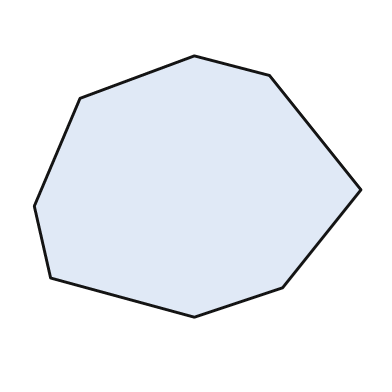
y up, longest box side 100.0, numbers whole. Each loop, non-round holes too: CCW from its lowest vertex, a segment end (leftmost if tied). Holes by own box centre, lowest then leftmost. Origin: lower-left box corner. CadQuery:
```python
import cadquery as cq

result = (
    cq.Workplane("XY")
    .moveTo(49.0, 0.0)
    .lineTo(76.0, 9.0)
    .lineTo(100.0, 39.0)
    .lineTo(72.0, 74.0)
    .lineTo(49.0, 80.0)
    .lineTo(14.0, 67.0)
    .lineTo(0.0, 34.0)
    .lineTo(5.0, 12.0)
    .close()
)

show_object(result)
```